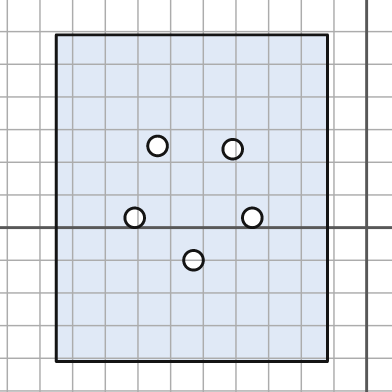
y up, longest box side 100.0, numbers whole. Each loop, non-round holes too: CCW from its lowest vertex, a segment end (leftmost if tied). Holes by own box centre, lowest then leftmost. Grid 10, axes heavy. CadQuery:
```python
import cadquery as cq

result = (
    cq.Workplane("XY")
    .moveTo(-95.0, -41.0)
    .lineTo(-12.0, -41.0)
    .lineTo(-12.0, 59.0)
    .lineTo(-95.0, 59.0)
    .close()
    .moveTo(-53.0, -10.0)
    .circle(3.0)
    .moveTo(-71.0, 3.0)
    .circle(3.0)
    .moveTo(-35.0, 3.0)
    .circle(3.0)
    .moveTo(-41.0, 24.0)
    .circle(3.0)
    .moveTo(-64.0, 25.0)
    .circle(3.0)
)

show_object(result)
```